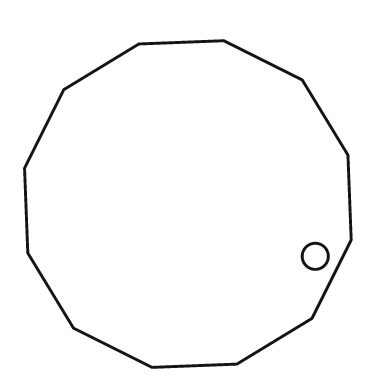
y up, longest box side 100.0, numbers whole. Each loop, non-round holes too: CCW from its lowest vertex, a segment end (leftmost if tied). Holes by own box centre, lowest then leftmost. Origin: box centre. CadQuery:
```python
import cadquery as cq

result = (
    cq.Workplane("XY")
    .moveTo(-11.0, -50.0)
    .lineTo(15.0, -49.0)
    .lineTo(38.0, -35.0)
    .lineTo(50.0, -11.0)
    .lineTo(49.0, 15.0)
    .lineTo(35.0, 38.0)
    .lineTo(11.0, 50.0)
    .lineTo(-15.0, 49.0)
    .lineTo(-38.0, 35.0)
    .lineTo(-50.0, 11.0)
    .lineTo(-49.0, -15.0)
    .lineTo(-35.0, -38.0)
    .close()
    .moveTo(39.0, -16.0)
    .circle(4.0)
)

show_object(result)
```